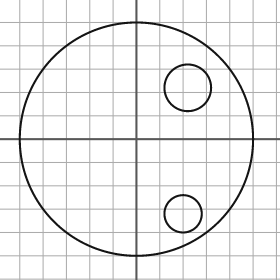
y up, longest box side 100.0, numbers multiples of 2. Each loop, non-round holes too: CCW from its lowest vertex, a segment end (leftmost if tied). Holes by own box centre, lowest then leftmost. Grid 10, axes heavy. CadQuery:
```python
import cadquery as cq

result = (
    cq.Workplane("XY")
    .moveTo(0.0, 0.0)
    .circle(50.0)
    .moveTo(20.0, -32.0)
    .circle(8.0)
    .moveTo(22.0, 22.0)
    .circle(10.0)
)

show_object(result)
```